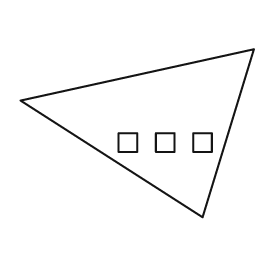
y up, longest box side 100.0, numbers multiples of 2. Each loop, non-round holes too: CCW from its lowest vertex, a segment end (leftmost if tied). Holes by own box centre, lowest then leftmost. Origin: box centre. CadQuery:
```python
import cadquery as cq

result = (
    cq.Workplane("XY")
    .moveTo(28.0, -36.0)
    .lineTo(50.0, 36.0)
    .lineTo(-50.0, 14.0)
    .close()
    .moveTo(-8.0, -8.0)
    .lineTo(0.0, -8.0)
    .lineTo(0.0, 0.0)
    .lineTo(-8.0, 0.0)
    .close()
    .moveTo(8.0, -8.0)
    .lineTo(16.0, -8.0)
    .lineTo(16.0, 0.0)
    .lineTo(8.0, 0.0)
    .close()
    .moveTo(24.0, -8.0)
    .lineTo(32.0, -8.0)
    .lineTo(32.0, 0.0)
    .lineTo(24.0, 0.0)
    .close()
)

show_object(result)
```